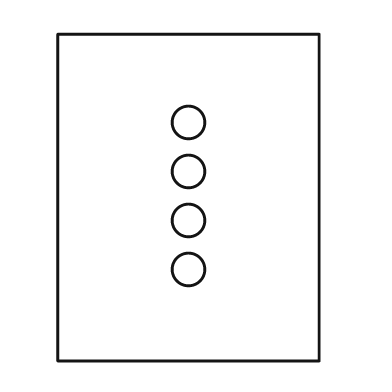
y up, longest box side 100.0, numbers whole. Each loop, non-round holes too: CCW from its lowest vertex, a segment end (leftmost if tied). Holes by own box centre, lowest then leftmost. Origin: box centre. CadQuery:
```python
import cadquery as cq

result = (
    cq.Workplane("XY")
    .moveTo(-40.0, -50.0)
    .lineTo(40.0, -50.0)
    .lineTo(40.0, 50.0)
    .lineTo(-40.0, 50.0)
    .close()
    .moveTo(0.0, -22.0)
    .circle(5.0)
    .moveTo(0.0, -7.0)
    .circle(5.0)
    .moveTo(0.0, 8.0)
    .circle(5.0)
    .moveTo(0.0, 23.0)
    .circle(5.0)
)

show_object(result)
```